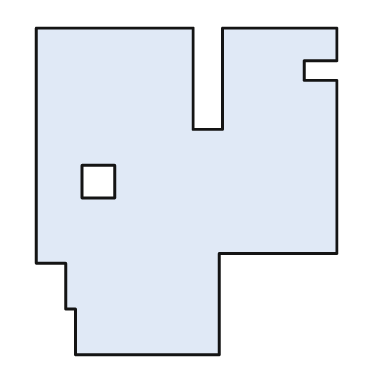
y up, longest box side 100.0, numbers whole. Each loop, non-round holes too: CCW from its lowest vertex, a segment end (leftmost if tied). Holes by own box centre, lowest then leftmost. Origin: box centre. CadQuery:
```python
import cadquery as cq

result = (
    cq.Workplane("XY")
    .moveTo(-34.0, -50.0)
    .lineTo(10.0, -50.0)
    .lineTo(10.0, -19.0)
    .lineTo(46.0, -19.0)
    .lineTo(46.0, 34.0)
    .lineTo(36.0, 34.0)
    .lineTo(36.0, 40.0)
    .lineTo(46.0, 40.0)
    .lineTo(46.0, 50.0)
    .lineTo(11.0, 50.0)
    .lineTo(11.0, 19.0)
    .lineTo(2.0, 19.0)
    .lineTo(2.0, 50.0)
    .lineTo(-46.0, 50.0)
    .lineTo(-46.0, -22.0)
    .lineTo(-37.0, -22.0)
    .lineTo(-37.0, -36.0)
    .lineTo(-34.0, -36.0)
    .close()
    .moveTo(-32.0, -2.0)
    .lineTo(-22.0, -2.0)
    .lineTo(-22.0, 8.0)
    .lineTo(-32.0, 8.0)
    .close()
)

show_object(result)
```